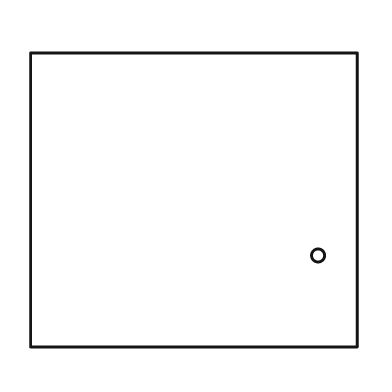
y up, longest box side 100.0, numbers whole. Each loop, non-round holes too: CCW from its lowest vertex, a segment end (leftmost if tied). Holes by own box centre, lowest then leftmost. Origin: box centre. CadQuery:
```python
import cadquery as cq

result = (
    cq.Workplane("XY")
    .moveTo(-50.0, -45.0)
    .lineTo(50.0, -45.0)
    .lineTo(50.0, 45.0)
    .lineTo(-50.0, 45.0)
    .close()
    .moveTo(38.0, -17.0)
    .circle(2.0)
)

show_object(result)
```